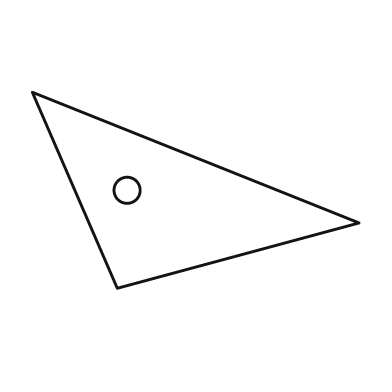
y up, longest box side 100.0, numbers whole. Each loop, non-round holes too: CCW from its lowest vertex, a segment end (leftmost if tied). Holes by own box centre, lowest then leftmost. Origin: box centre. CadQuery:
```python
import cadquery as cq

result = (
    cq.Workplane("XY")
    .moveTo(-24.0, -30.0)
    .lineTo(50.0, -10.0)
    .lineTo(-50.0, 30.0)
    .close()
    .moveTo(-21.0, 0.0)
    .circle(4.0)
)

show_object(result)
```